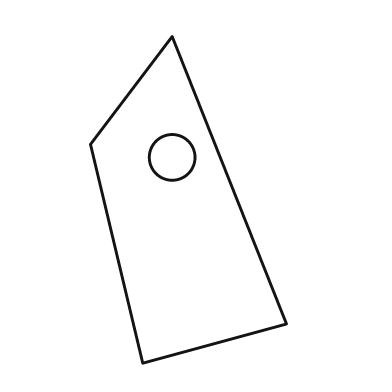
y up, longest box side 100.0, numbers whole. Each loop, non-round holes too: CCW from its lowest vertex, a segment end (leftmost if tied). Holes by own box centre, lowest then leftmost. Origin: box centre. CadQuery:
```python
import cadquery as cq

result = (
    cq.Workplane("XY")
    .moveTo(-14.0, -50.0)
    .lineTo(30.0, -38.0)
    .lineTo(-5.0, 50.0)
    .lineTo(-30.0, 17.0)
    .close()
    .moveTo(-5.0, 13.0)
    .circle(7.0)
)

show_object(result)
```